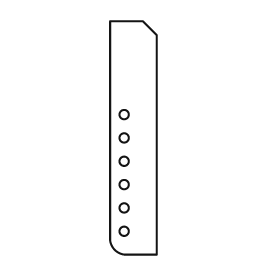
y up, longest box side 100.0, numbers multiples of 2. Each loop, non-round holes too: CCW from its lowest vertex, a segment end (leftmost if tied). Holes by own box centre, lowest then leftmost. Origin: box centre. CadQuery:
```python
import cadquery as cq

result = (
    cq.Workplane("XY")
    .moveTo(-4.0, -50.0)
    .lineTo(10.0, -50.0)
    .lineTo(10.0, 44.0)
    .lineTo(4.0, 50.0)
    .lineTo(-10.0, 50.0)
    .lineTo(-10.0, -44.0)
    .threePointArc((-8.0, -48.0), (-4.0, -50.0))
    .close()
    .moveTo(-4.0, -40.0)
    .circle(2.0)
    .moveTo(-4.0, -30.0)
    .circle(2.0)
    .moveTo(-4.0, -20.0)
    .circle(2.0)
    .moveTo(-4.0, -10.0)
    .circle(2.0)
    .moveTo(-4.0, 0.0)
    .circle(2.0)
    .moveTo(-4.0, 10.0)
    .circle(2.0)
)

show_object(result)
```